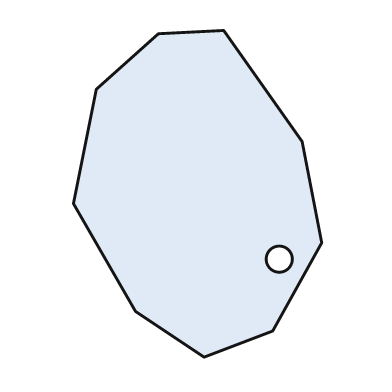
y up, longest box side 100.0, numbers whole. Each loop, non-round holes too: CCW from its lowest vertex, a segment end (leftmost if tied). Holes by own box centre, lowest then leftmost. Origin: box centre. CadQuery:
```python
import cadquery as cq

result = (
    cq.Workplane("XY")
    .moveTo(2.0, -50.0)
    .lineTo(23.0, -42.0)
    .lineTo(38.0, -15.0)
    .lineTo(32.0, 16.0)
    .lineTo(8.0, 50.0)
    .lineTo(-12.0, 49.0)
    .lineTo(-31.0, 32.0)
    .lineTo(-38.0, -3.0)
    .lineTo(-19.0, -36.0)
    .close()
    .moveTo(25.0, -20.0)
    .circle(4.0)
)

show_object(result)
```